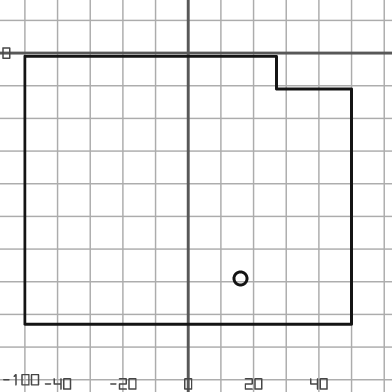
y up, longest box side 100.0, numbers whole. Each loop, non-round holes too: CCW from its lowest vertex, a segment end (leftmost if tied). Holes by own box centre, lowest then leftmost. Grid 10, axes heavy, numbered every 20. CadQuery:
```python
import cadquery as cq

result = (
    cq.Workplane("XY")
    .moveTo(-50.0, -83.0)
    .lineTo(50.0, -83.0)
    .lineTo(50.0, -11.0)
    .lineTo(27.0, -11.0)
    .lineTo(27.0, -1.0)
    .lineTo(-50.0, -1.0)
    .close()
    .moveTo(16.0, -69.0)
    .circle(2.0)
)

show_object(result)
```